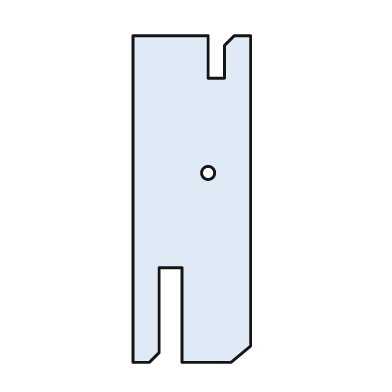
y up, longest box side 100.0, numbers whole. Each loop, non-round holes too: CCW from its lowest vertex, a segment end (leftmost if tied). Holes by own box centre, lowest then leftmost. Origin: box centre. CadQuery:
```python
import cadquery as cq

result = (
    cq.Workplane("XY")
    .moveTo(-18.0, -50.0)
    .lineTo(-13.0, -50.0)
    .lineTo(-10.0, -47.0)
    .lineTo(-10.0, -21.0)
    .lineTo(-3.0, -21.0)
    .lineTo(-3.0, -50.0)
    .lineTo(12.0, -50.0)
    .lineTo(18.0, -45.0)
    .lineTo(18.0, 50.0)
    .lineTo(13.0, 50.0)
    .lineTo(10.0, 47.0)
    .lineTo(10.0, 37.0)
    .lineTo(5.0, 37.0)
    .lineTo(5.0, 50.0)
    .lineTo(-18.0, 50.0)
    .close()
    .moveTo(5.0, 8.0)
    .circle(2.0)
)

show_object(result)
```